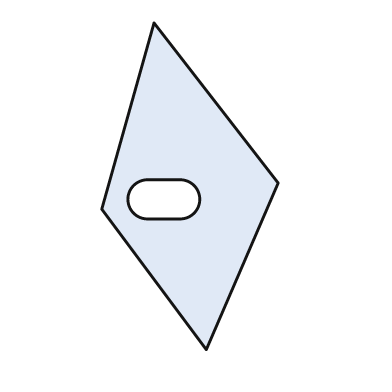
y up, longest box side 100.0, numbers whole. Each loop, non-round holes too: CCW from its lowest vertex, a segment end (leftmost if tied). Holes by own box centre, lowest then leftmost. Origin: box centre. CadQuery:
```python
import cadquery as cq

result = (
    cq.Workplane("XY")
    .moveTo(5.0, -50.0)
    .lineTo(27.0, 1.0)
    .lineTo(-11.0, 50.0)
    .lineTo(-27.0, -7.0)
    .close()
    .moveTo(-13.0, -10.0)
    .lineTo(-3.0, -10.0)
    .threePointArc((3.0, -4.0), (-3.0, 2.0))
    .lineTo(-13.0, 2.0)
    .threePointArc((-19.0, -4.0), (-13.0, -10.0))
    .close()
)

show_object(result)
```